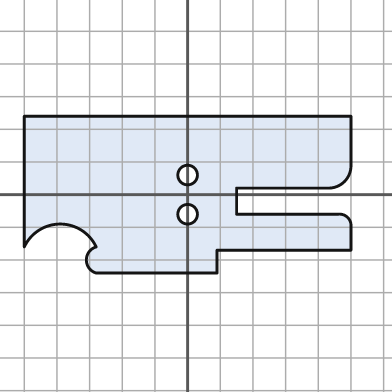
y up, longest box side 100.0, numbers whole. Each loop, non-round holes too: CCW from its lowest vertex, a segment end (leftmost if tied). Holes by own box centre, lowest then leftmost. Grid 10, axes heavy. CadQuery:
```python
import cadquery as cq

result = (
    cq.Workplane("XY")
    .moveTo(-28.0, -24.0)
    .lineTo(9.0, -24.0)
    .lineTo(9.0, -17.0)
    .lineTo(50.0, -17.0)
    .lineTo(50.0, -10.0)
    .threePointArc((49.0, -7.0), (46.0, -6.0))
    .lineTo(15.0, -6.0)
    .lineTo(15.0, 2.0)
    .lineTo(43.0, 2.0)
    .threePointArc((48.0, 4.0), (50.0, 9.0))
    .lineTo(50.0, 24.0)
    .lineTo(-50.0, 24.0)
    .lineTo(-50.0, -16.0)
    .threePointArc((-39.0, -9.0), (-28.0, -16.0))
    .threePointArc((-31.0, -20.0), (-28.0, -24.0))
    .close()
    .moveTo(0.0, -6.0)
    .circle(3.0)
    .moveTo(0.0, 6.0)
    .circle(3.0)
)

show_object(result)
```